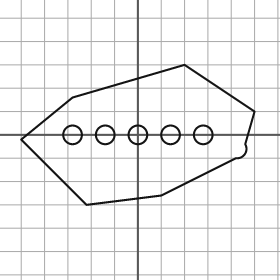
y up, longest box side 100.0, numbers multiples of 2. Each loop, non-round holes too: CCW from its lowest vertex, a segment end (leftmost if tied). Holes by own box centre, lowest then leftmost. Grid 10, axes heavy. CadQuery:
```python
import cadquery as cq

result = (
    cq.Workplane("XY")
    .moveTo(-22.0, -30.0)
    .lineTo(10.0, -26.0)
    .lineTo(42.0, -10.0)
    .threePointArc((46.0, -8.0), (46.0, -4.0))
    .lineTo(50.0, 10.0)
    .lineTo(20.0, 30.0)
    .lineTo(-28.0, 16.0)
    .lineTo(-50.0, -2.0)
    .close()
    .moveTo(-28.0, 0.0)
    .circle(4.0)
    .moveTo(-14.0, 0.0)
    .circle(4.0)
    .moveTo(0.0, 0.0)
    .circle(4.0)
    .moveTo(14.0, 0.0)
    .circle(4.0)
    .moveTo(28.0, 0.0)
    .circle(4.0)
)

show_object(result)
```